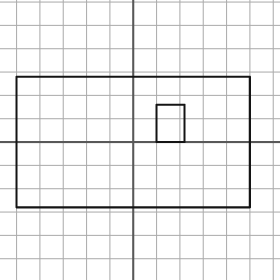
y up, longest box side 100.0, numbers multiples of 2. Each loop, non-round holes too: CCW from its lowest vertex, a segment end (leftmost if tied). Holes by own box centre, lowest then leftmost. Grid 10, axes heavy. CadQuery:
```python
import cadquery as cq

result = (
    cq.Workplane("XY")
    .moveTo(-50.0, -28.0)
    .lineTo(50.0, -28.0)
    .lineTo(50.0, 28.0)
    .lineTo(-50.0, 28.0)
    .close()
    .moveTo(10.0, 0.0)
    .lineTo(22.0, 0.0)
    .lineTo(22.0, 16.0)
    .lineTo(10.0, 16.0)
    .close()
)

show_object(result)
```